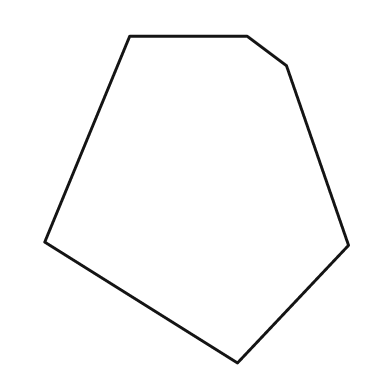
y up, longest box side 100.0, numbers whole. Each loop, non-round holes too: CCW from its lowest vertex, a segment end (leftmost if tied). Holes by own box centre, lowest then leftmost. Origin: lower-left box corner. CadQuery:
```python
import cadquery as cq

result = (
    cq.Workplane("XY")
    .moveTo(59.0, 0.0)
    .lineTo(93.0, 36.0)
    .lineTo(74.0, 91.0)
    .lineTo(62.0, 100.0)
    .lineTo(26.0, 100.0)
    .lineTo(0.0, 37.0)
    .close()
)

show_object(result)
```